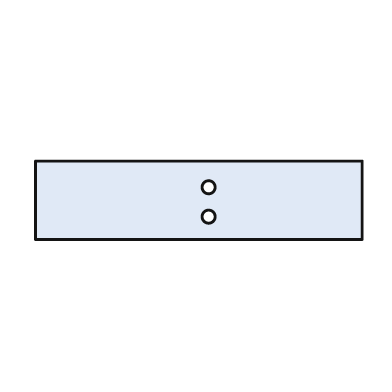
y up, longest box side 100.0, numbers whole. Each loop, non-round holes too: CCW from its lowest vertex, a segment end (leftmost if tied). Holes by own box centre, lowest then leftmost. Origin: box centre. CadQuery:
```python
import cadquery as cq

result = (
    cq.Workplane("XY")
    .moveTo(-50.0, -12.0)
    .lineTo(50.0, -12.0)
    .lineTo(50.0, 12.0)
    .lineTo(-50.0, 12.0)
    .close()
    .moveTo(3.0, -5.0)
    .circle(2.0)
    .moveTo(3.0, 4.0)
    .circle(2.0)
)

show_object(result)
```